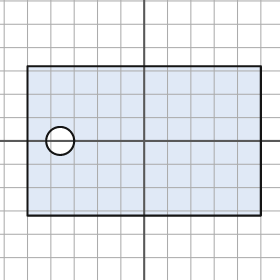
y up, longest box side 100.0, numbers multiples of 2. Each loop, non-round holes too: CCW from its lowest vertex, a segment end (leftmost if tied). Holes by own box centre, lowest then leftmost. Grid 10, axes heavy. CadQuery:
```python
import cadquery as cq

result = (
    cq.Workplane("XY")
    .moveTo(-50.0, -32.0)
    .lineTo(50.0, -32.0)
    .lineTo(50.0, 32.0)
    .lineTo(-50.0, 32.0)
    .close()
    .moveTo(-36.0, 0.0)
    .circle(6.0)
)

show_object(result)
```